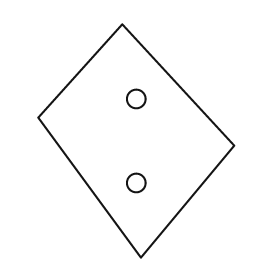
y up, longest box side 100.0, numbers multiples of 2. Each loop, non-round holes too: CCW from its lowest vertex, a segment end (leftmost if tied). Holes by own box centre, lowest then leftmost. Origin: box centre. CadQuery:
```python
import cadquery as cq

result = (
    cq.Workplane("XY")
    .moveTo(2.0, -50.0)
    .lineTo(42.0, -2.0)
    .lineTo(-6.0, 50.0)
    .lineTo(-42.0, 10.0)
    .close()
    .moveTo(0.0, -18.0)
    .circle(4.0)
    .moveTo(0.0, 18.0)
    .circle(4.0)
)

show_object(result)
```